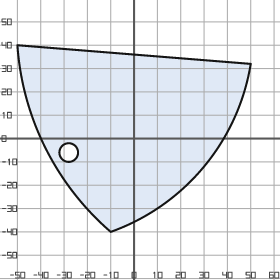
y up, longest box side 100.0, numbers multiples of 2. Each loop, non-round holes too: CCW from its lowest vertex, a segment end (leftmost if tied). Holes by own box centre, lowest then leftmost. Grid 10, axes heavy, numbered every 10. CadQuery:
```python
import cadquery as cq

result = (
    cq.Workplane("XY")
    .moveTo(-10.0, -40.0)
    .threePointArc((30.0, -12.0), (50.0, 32.0))
    .lineTo(-50.0, 40.0)
    .threePointArc((-38.0, -4.0), (-10.0, -40.0))
    .close()
    .moveTo(-28.0, -6.0)
    .circle(4.0)
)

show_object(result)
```